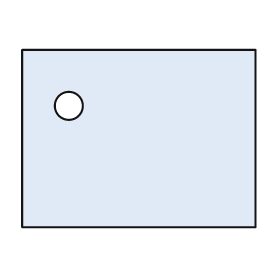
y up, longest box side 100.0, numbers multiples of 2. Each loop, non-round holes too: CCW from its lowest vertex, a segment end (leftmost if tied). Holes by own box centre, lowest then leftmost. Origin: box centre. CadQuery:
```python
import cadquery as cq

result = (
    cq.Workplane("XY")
    .moveTo(-50.0, -38.0)
    .lineTo(50.0, -38.0)
    .lineTo(50.0, 38.0)
    .lineTo(-50.0, 38.0)
    .close()
    .moveTo(-30.0, 14.0)
    .circle(6.0)
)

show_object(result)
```